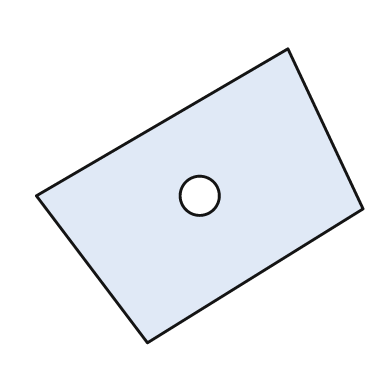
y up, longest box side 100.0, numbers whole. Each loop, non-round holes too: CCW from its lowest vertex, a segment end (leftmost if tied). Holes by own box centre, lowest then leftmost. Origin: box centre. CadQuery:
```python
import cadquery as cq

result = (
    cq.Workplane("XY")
    .moveTo(-16.0, -45.0)
    .lineTo(50.0, -4.0)
    .lineTo(27.0, 45.0)
    .lineTo(-50.0, 0.0)
    .close()
    .moveTo(0.0, 0.0)
    .circle(6.0)
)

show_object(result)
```